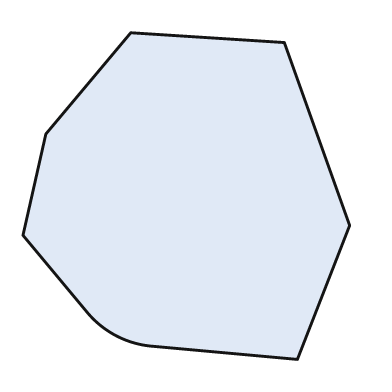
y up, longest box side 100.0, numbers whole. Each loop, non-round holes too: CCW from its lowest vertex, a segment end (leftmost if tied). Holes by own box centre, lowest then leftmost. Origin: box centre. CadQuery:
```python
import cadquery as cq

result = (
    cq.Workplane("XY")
    .moveTo(34.0, -50.0)
    .lineTo(50.0, -9.0)
    .lineTo(30.0, 47.0)
    .lineTo(-17.0, 50.0)
    .lineTo(-43.0, 19.0)
    .lineTo(-50.0, -12.0)
    .lineTo(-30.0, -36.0)
    .threePointArc((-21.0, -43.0), (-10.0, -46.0))
    .close()
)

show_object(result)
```